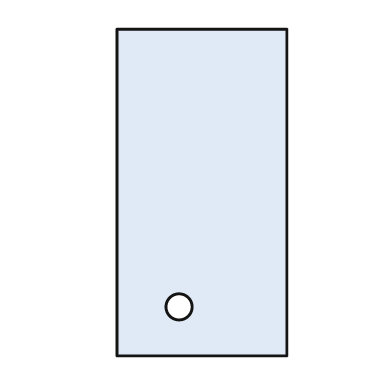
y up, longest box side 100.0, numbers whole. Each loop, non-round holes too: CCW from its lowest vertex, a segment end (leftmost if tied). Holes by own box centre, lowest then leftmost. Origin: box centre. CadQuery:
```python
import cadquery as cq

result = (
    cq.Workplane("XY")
    .moveTo(-26.0, -50.0)
    .lineTo(26.0, -50.0)
    .lineTo(26.0, 50.0)
    .lineTo(-26.0, 50.0)
    .close()
    .moveTo(-7.0, -35.0)
    .circle(4.0)
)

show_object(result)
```